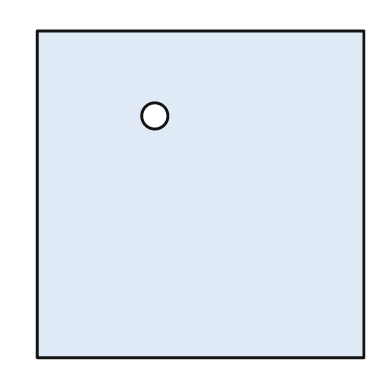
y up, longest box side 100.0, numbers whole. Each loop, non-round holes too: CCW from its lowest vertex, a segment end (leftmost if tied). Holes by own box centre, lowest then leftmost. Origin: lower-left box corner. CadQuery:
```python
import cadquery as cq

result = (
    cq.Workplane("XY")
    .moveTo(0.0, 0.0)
    .lineTo(100.0, 0.0)
    .lineTo(100.0, 100.0)
    .lineTo(0.0, 100.0)
    .close()
    .moveTo(36.0, 74.0)
    .circle(4.0)
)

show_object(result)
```